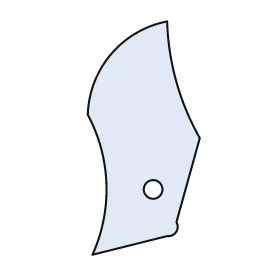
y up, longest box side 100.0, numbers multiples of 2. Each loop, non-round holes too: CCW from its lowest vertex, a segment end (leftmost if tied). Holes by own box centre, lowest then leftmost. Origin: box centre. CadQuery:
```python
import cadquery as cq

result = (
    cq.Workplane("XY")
    .moveTo(-22.0, -50.0)
    .lineTo(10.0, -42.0)
    .threePointArc((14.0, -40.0), (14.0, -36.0))
    .lineTo(24.0, 0.0)
    .threePointArc((14.0, 24.0), (10.0, 50.0))
    .threePointArc((-14.0, 36.0), (-24.0, 10.0))
    .threePointArc((-16.0, -20.0), (-22.0, -50.0))
    .close()
    .moveTo(4.0, -22.0)
    .circle(4.0)
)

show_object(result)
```